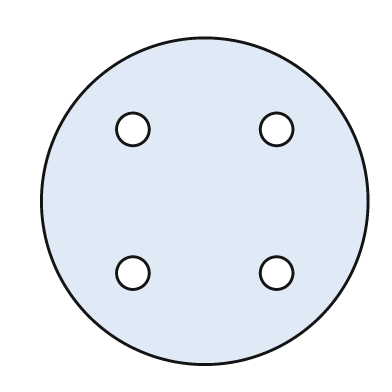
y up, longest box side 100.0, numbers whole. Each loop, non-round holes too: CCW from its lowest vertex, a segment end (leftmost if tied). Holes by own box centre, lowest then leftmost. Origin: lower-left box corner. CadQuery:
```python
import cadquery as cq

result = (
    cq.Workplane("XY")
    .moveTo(50.0, 50.0)
    .circle(50.0)
    .moveTo(28.0, 28.0)
    .circle(5.0)
    .moveTo(72.0, 28.0)
    .circle(5.0)
    .moveTo(28.0, 72.0)
    .circle(5.0)
    .moveTo(72.0, 72.0)
    .circle(5.0)
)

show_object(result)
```